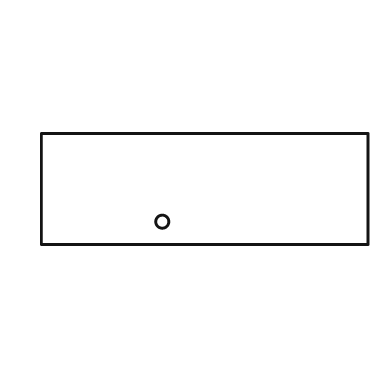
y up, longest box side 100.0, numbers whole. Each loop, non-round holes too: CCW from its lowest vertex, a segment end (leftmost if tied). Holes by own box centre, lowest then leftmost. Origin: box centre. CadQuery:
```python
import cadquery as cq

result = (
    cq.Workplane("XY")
    .moveTo(-50.0, -17.0)
    .lineTo(50.0, -17.0)
    .lineTo(50.0, 17.0)
    .lineTo(-50.0, 17.0)
    .close()
    .moveTo(-13.0, -10.0)
    .circle(2.0)
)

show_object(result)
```